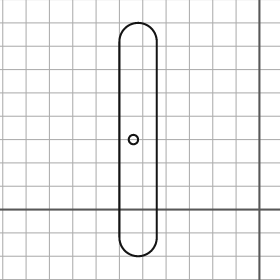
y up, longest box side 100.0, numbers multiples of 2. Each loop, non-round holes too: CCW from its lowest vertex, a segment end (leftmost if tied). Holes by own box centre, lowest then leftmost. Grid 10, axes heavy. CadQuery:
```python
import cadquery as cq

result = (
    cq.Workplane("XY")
    .moveTo(-60.0, -12.0)
    .threePointArc((-52.0, -20.0), (-44.0, -12.0))
    .lineTo(-44.0, 72.0)
    .threePointArc((-52.0, 80.0), (-60.0, 72.0))
    .close()
    .moveTo(-54.0, 30.0)
    .circle(2.0)
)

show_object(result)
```